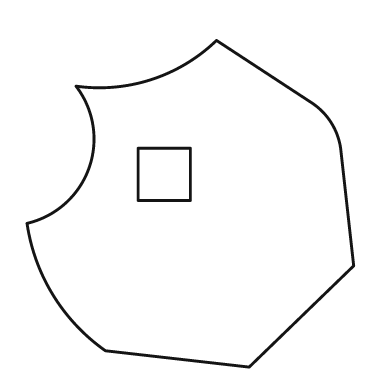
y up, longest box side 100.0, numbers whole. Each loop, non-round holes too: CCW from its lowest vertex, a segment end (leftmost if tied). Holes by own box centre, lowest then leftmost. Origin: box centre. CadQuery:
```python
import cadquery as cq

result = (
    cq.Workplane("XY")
    .moveTo(18.0, -50.0)
    .lineTo(50.0, -19.0)
    .lineTo(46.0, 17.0)
    .threePointArc((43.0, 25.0), (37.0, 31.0))
    .lineTo(8.0, 50.0)
    .threePointArc((-12.0, 38.0), (-35.0, 36.0))
    .threePointArc((-31.0, 11.0), (-50.0, -6.0))
    .threePointArc((-42.0, -28.0), (-26.0, -45.0))
    .close()
    .moveTo(-16.0, 1.0)
    .lineTo(0.0, 1.0)
    .lineTo(0.0, 17.0)
    .lineTo(-16.0, 17.0)
    .close()
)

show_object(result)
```